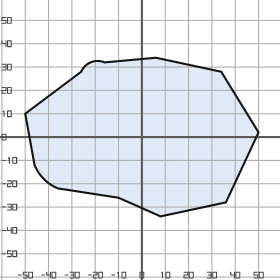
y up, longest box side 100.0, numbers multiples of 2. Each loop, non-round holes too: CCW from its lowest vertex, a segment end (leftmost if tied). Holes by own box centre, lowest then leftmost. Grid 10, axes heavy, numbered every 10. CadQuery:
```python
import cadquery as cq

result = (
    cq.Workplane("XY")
    .moveTo(8.0, -34.0)
    .lineTo(36.0, -28.0)
    .lineTo(50.0, 2.0)
    .lineTo(34.0, 28.0)
    .lineTo(6.0, 34.0)
    .lineTo(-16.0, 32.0)
    .threePointArc((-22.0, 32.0), (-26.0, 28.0))
    .lineTo(-50.0, 10.0)
    .lineTo(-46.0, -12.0)
    .threePointArc((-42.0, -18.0), (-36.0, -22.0))
    .lineTo(-10.0, -26.0)
    .close()
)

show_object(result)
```